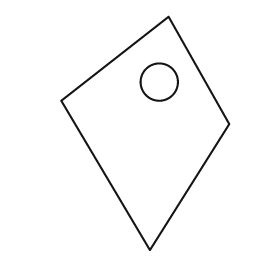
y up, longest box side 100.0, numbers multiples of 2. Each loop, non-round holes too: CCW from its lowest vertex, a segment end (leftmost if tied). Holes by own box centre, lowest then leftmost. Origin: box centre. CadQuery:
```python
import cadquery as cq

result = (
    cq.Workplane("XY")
    .moveTo(2.0, -50.0)
    .lineTo(36.0, 4.0)
    .lineTo(10.0, 50.0)
    .lineTo(-36.0, 14.0)
    .close()
    .moveTo(6.0, 22.0)
    .circle(8.0)
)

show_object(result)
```